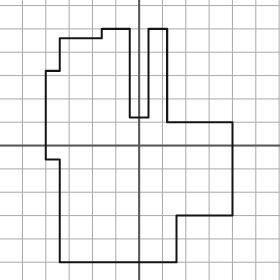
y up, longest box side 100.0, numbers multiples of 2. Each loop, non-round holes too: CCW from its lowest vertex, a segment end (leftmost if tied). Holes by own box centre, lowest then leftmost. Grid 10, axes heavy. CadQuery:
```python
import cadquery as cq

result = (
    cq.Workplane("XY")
    .moveTo(-34.0, -50.0)
    .lineTo(16.0, -50.0)
    .lineTo(16.0, -30.0)
    .lineTo(40.0, -30.0)
    .lineTo(40.0, 10.0)
    .lineTo(12.0, 10.0)
    .lineTo(12.0, 50.0)
    .lineTo(4.0, 50.0)
    .lineTo(4.0, 12.0)
    .lineTo(-4.0, 12.0)
    .lineTo(-4.0, 50.0)
    .lineTo(-16.0, 50.0)
    .lineTo(-16.0, 46.0)
    .lineTo(-34.0, 46.0)
    .lineTo(-34.0, 32.0)
    .lineTo(-40.0, 32.0)
    .lineTo(-40.0, -6.0)
    .lineTo(-34.0, -6.0)
    .close()
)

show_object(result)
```